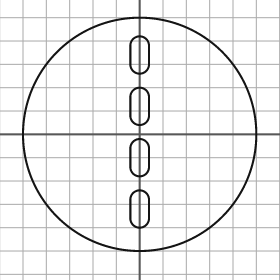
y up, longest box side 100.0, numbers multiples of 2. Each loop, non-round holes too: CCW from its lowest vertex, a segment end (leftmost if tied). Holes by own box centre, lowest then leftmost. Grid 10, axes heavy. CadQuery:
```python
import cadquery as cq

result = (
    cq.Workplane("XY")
    .moveTo(0.0, 0.0)
    .circle(50.0)
    .moveTo(-4.0, -36.0)
    .threePointArc((0.0, -40.0), (4.0, -36.0))
    .lineTo(4.0, -28.0)
    .threePointArc((0.0, -24.0), (-4.0, -28.0))
    .close()
    .moveTo(-4.0, -14.0)
    .threePointArc((0.0, -18.0), (4.0, -14.0))
    .lineTo(4.0, -6.0)
    .threePointArc((0.0, -2.0), (-4.0, -6.0))
    .close()
    .moveTo(-4.0, 8.0)
    .threePointArc((0.0, 4.0), (4.0, 8.0))
    .lineTo(4.0, 16.0)
    .threePointArc((0.0, 20.0), (-4.0, 16.0))
    .close()
    .moveTo(-4.0, 30.0)
    .threePointArc((0.0, 26.0), (4.0, 30.0))
    .lineTo(4.0, 38.0)
    .threePointArc((0.0, 42.0), (-4.0, 38.0))
    .close()
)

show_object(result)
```